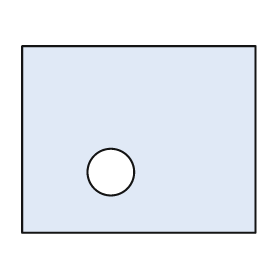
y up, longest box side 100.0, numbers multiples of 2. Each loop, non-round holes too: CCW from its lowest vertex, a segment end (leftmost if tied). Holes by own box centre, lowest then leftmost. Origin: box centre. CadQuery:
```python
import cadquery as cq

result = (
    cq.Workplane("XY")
    .moveTo(-50.0, -40.0)
    .lineTo(50.0, -40.0)
    .lineTo(50.0, 40.0)
    .lineTo(-50.0, 40.0)
    .close()
    .moveTo(-12.0, -14.0)
    .circle(10.0)
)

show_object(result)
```